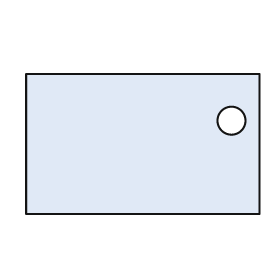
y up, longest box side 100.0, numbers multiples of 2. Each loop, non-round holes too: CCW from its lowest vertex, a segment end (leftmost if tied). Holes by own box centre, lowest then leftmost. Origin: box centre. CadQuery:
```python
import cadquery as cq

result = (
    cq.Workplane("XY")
    .moveTo(-50.0, -30.0)
    .lineTo(50.0, -30.0)
    .lineTo(50.0, 30.0)
    .lineTo(-50.0, 30.0)
    .close()
    .moveTo(38.0, 10.0)
    .circle(6.0)
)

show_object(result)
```